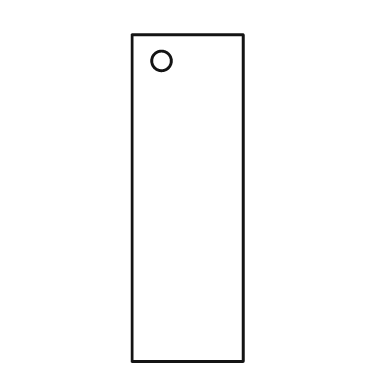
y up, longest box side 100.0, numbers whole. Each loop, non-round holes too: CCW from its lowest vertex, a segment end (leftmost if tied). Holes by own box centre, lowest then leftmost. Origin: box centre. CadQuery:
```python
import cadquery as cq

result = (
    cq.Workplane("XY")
    .moveTo(-17.0, -50.0)
    .lineTo(17.0, -50.0)
    .lineTo(17.0, 50.0)
    .lineTo(-17.0, 50.0)
    .close()
    .moveTo(-8.0, 42.0)
    .circle(3.0)
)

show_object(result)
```